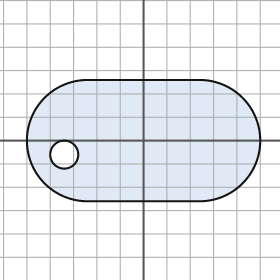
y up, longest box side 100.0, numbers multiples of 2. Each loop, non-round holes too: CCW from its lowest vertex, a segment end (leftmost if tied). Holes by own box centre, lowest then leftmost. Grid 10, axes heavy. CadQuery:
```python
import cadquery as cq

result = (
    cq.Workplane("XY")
    .moveTo(-24.0, -26.0)
    .lineTo(24.0, -26.0)
    .threePointArc((50.0, 0.0), (24.0, 26.0))
    .lineTo(-24.0, 26.0)
    .threePointArc((-50.0, 0.0), (-24.0, -26.0))
    .close()
    .moveTo(-34.0, -6.0)
    .circle(6.0)
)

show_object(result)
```